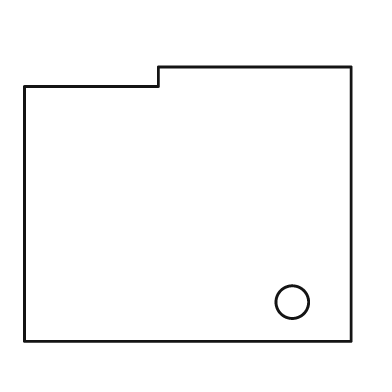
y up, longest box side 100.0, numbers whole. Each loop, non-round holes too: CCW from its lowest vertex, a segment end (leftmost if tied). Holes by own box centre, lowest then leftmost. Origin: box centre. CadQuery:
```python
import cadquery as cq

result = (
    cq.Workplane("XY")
    .moveTo(-50.0, -42.0)
    .lineTo(50.0, -42.0)
    .lineTo(50.0, 42.0)
    .lineTo(-9.0, 42.0)
    .lineTo(-9.0, 36.0)
    .lineTo(-50.0, 36.0)
    .close()
    .moveTo(32.0, -30.0)
    .circle(5.0)
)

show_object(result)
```